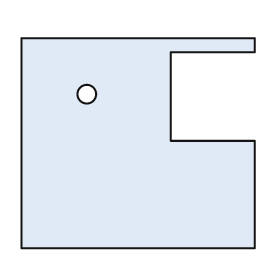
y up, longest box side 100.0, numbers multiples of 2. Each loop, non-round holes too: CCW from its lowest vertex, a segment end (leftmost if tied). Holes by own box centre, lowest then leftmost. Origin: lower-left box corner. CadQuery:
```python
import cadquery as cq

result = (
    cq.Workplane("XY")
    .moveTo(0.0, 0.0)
    .lineTo(100.0, 0.0)
    .lineTo(100.0, 46.0)
    .lineTo(64.0, 46.0)
    .lineTo(64.0, 84.0)
    .lineTo(100.0, 84.0)
    .lineTo(100.0, 90.0)
    .lineTo(0.0, 90.0)
    .close()
    .moveTo(28.0, 66.0)
    .circle(4.0)
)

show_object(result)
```